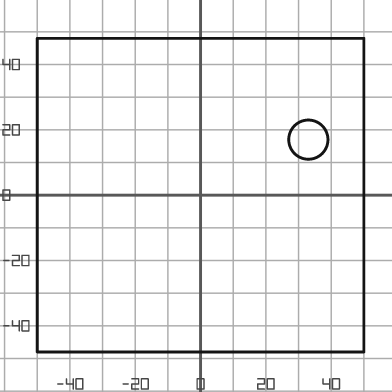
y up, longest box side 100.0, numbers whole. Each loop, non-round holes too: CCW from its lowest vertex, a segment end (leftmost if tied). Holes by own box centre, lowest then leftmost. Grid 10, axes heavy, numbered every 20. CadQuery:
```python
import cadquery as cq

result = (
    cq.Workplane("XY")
    .moveTo(-50.0, -48.0)
    .lineTo(50.0, -48.0)
    .lineTo(50.0, 48.0)
    .lineTo(-50.0, 48.0)
    .close()
    .moveTo(33.0, 17.0)
    .circle(6.0)
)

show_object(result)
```